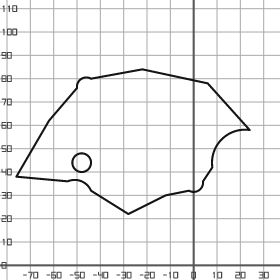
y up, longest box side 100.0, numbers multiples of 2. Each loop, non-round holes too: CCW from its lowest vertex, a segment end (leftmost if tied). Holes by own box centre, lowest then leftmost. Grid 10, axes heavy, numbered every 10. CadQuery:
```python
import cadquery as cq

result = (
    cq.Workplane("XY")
    .moveTo(-28.0, 22.0)
    .lineTo(-12.0, 30.0)
    .lineTo(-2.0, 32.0)
    .threePointArc((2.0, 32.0), (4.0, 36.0))
    .lineTo(8.0, 42.0)
    .threePointArc((12.0, 54.0), (24.0, 58.0))
    .lineTo(6.0, 78.0)
    .lineTo(-22.0, 84.0)
    .lineTo(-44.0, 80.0)
    .threePointArc((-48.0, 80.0), (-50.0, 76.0))
    .lineTo(-62.0, 62.0)
    .lineTo(-76.0, 38.0)
    .lineTo(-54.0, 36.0)
    .threePointArc((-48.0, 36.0), (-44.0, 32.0))
    .close()
    .moveTo(-48.0, 44.0)
    .circle(4.0)
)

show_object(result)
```